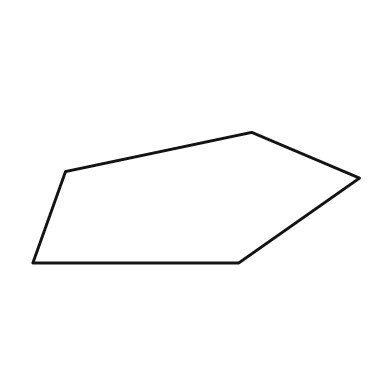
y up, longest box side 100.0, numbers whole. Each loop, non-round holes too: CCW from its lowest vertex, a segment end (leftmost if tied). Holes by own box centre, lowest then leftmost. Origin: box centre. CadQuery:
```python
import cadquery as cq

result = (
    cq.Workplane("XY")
    .moveTo(-50.0, -20.0)
    .lineTo(13.0, -20.0)
    .lineTo(50.0, 6.0)
    .lineTo(17.0, 20.0)
    .lineTo(-40.0, 8.0)
    .close()
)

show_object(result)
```